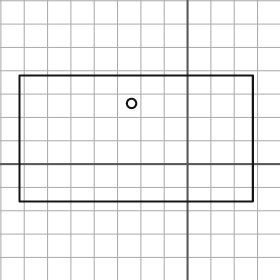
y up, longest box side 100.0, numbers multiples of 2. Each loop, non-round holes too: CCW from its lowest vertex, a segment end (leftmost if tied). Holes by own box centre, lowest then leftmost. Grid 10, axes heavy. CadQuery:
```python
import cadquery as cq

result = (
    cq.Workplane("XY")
    .moveTo(-72.0, -16.0)
    .lineTo(28.0, -16.0)
    .lineTo(28.0, 38.0)
    .lineTo(-72.0, 38.0)
    .close()
    .moveTo(-24.0, 26.0)
    .circle(2.0)
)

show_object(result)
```